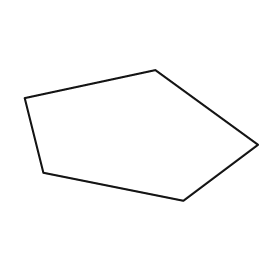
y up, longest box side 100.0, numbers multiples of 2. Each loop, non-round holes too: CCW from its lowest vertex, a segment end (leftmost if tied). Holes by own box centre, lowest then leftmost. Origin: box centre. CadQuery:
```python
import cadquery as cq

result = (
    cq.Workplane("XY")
    .moveTo(18.0, -28.0)
    .lineTo(50.0, -4.0)
    .lineTo(6.0, 28.0)
    .lineTo(-50.0, 16.0)
    .lineTo(-42.0, -16.0)
    .close()
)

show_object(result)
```